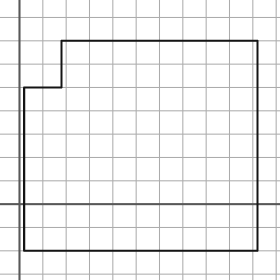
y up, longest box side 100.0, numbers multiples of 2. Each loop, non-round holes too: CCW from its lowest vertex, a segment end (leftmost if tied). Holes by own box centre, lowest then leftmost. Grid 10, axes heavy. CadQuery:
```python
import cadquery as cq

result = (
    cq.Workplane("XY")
    .moveTo(2.0, -20.0)
    .lineTo(102.0, -20.0)
    .lineTo(102.0, 70.0)
    .lineTo(18.0, 70.0)
    .lineTo(18.0, 50.0)
    .lineTo(2.0, 50.0)
    .close()
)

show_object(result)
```